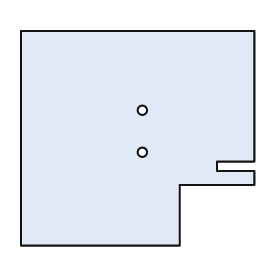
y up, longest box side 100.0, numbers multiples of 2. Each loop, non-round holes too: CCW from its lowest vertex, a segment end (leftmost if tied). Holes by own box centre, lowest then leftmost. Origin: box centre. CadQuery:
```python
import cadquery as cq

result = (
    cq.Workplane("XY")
    .moveTo(-50.0, -46.0)
    .lineTo(18.0, -46.0)
    .lineTo(18.0, -20.0)
    .lineTo(50.0, -20.0)
    .lineTo(50.0, -14.0)
    .lineTo(34.0, -14.0)
    .lineTo(34.0, -10.0)
    .lineTo(50.0, -10.0)
    .lineTo(50.0, 46.0)
    .lineTo(-50.0, 46.0)
    .close()
    .moveTo(2.0, -6.0)
    .circle(2.0)
    .moveTo(2.0, 12.0)
    .circle(2.0)
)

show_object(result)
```